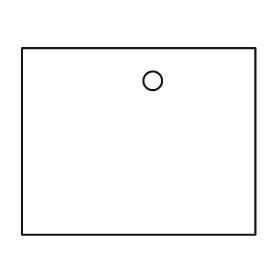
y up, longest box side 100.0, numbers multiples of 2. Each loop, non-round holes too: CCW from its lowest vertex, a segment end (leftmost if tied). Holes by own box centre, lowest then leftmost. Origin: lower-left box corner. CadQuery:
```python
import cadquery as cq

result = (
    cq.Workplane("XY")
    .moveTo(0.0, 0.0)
    .lineTo(100.0, 0.0)
    .lineTo(100.0, 80.0)
    .lineTo(0.0, 80.0)
    .close()
    .moveTo(56.0, 66.0)
    .circle(4.0)
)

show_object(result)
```